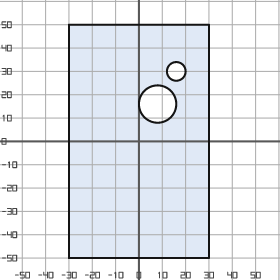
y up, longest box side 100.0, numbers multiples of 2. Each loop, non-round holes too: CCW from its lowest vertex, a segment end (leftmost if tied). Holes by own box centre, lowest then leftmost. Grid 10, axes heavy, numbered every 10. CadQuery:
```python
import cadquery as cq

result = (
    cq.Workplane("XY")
    .moveTo(-30.0, -50.0)
    .lineTo(30.0, -50.0)
    .lineTo(30.0, 50.0)
    .lineTo(-30.0, 50.0)
    .close()
    .moveTo(8.0, 16.0)
    .circle(8.0)
    .moveTo(16.0, 30.0)
    .circle(4.0)
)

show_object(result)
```